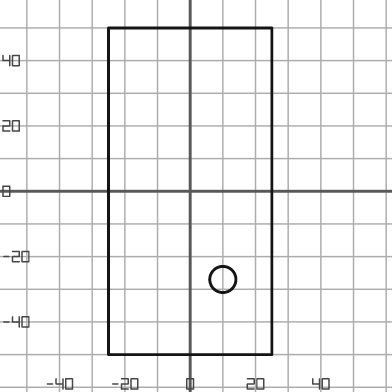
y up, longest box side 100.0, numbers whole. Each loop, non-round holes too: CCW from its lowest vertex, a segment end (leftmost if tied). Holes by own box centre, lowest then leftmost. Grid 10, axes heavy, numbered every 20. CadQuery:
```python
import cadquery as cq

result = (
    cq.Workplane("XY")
    .moveTo(-25.0, -50.0)
    .lineTo(25.0, -50.0)
    .lineTo(25.0, 50.0)
    .lineTo(-25.0, 50.0)
    .close()
    .moveTo(10.0, -27.0)
    .circle(4.0)
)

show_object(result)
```